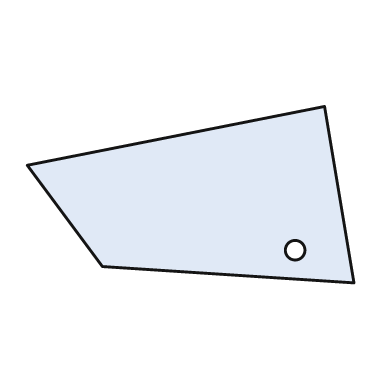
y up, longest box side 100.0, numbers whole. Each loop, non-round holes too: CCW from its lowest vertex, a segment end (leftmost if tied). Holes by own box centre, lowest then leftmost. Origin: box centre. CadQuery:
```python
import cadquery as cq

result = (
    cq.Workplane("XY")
    .moveTo(50.0, -27.0)
    .lineTo(41.0, 27.0)
    .lineTo(-50.0, 9.0)
    .lineTo(-27.0, -22.0)
    .close()
    .moveTo(32.0, -17.0)
    .circle(3.0)
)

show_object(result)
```